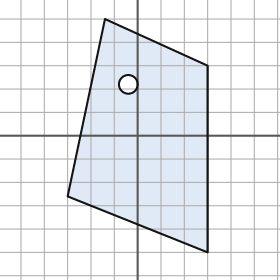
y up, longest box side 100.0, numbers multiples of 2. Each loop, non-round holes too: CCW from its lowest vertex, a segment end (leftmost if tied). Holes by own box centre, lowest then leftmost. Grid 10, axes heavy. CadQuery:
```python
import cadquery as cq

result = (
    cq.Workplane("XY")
    .moveTo(30.0, -50.0)
    .lineTo(30.0, 30.0)
    .lineTo(-14.0, 50.0)
    .lineTo(-30.0, -26.0)
    .close()
    .moveTo(-4.0, 22.0)
    .circle(4.0)
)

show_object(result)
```